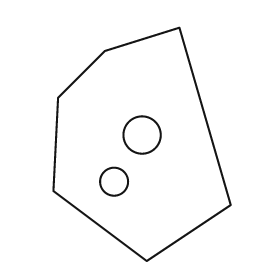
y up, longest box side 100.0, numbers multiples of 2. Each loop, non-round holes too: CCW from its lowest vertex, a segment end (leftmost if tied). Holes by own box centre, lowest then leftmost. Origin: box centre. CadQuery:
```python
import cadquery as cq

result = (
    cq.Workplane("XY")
    .moveTo(2.0, -50.0)
    .lineTo(38.0, -26.0)
    .lineTo(16.0, 50.0)
    .lineTo(-16.0, 40.0)
    .lineTo(-36.0, 20.0)
    .lineTo(-38.0, -20.0)
    .close()
    .moveTo(-12.0, -16.0)
    .circle(6.0)
    .moveTo(0.0, 4.0)
    .circle(8.0)
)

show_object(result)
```